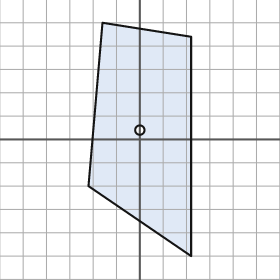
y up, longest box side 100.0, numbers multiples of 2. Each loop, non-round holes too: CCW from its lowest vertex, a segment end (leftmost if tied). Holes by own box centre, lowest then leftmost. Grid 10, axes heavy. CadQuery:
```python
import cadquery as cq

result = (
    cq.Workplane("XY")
    .moveTo(22.0, -50.0)
    .lineTo(22.0, 44.0)
    .lineTo(-16.0, 50.0)
    .lineTo(-22.0, -20.0)
    .close()
    .moveTo(0.0, 4.0)
    .circle(2.0)
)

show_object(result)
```